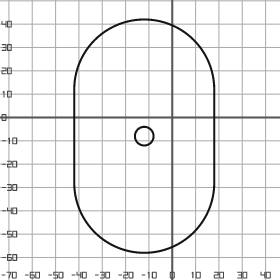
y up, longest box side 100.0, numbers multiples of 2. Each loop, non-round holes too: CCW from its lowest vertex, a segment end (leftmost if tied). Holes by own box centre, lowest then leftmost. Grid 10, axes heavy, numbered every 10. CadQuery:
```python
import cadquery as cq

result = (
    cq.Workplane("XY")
    .moveTo(-42.0, -28.0)
    .threePointArc((-12.0, -58.0), (18.0, -28.0))
    .lineTo(18.0, 12.0)
    .threePointArc((-12.0, 42.0), (-42.0, 12.0))
    .close()
    .moveTo(-12.0, -8.0)
    .circle(4.0)
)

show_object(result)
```